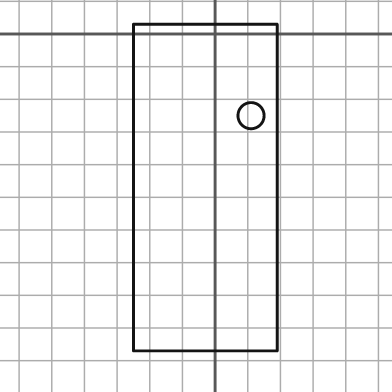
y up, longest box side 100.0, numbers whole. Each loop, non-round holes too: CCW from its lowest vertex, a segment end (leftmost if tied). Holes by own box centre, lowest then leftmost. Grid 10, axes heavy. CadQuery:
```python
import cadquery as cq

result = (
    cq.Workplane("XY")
    .moveTo(-25.0, -97.0)
    .lineTo(19.0, -97.0)
    .lineTo(19.0, 3.0)
    .lineTo(-25.0, 3.0)
    .close()
    .moveTo(11.0, -25.0)
    .circle(4.0)
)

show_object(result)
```